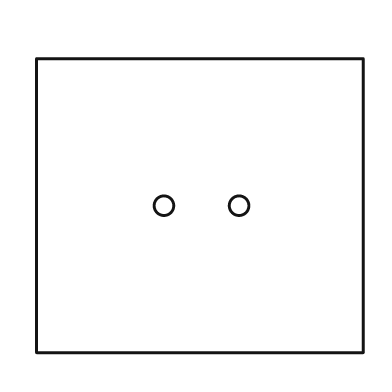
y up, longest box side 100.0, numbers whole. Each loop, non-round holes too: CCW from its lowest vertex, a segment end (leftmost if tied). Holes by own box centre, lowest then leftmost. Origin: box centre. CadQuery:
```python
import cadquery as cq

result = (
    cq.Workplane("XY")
    .moveTo(-50.0, -45.0)
    .lineTo(50.0, -45.0)
    .lineTo(50.0, 45.0)
    .lineTo(-50.0, 45.0)
    .close()
    .moveTo(-11.0, 0.0)
    .circle(3.0)
    .moveTo(12.0, 0.0)
    .circle(3.0)
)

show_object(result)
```